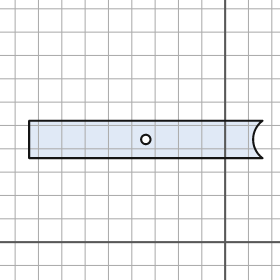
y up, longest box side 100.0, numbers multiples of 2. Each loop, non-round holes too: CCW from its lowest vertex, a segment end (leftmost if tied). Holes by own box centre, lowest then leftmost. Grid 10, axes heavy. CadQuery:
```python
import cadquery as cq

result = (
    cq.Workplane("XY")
    .moveTo(-84.0, 36.0)
    .lineTo(16.0, 36.0)
    .threePointArc((12.0, 44.0), (16.0, 52.0))
    .lineTo(-84.0, 52.0)
    .close()
    .moveTo(-34.0, 44.0)
    .circle(2.0)
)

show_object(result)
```